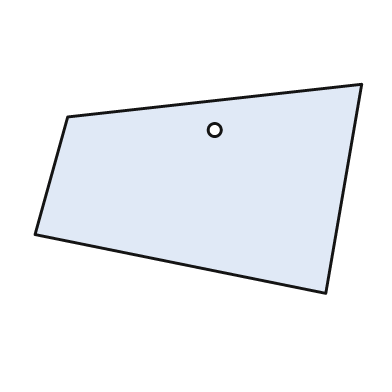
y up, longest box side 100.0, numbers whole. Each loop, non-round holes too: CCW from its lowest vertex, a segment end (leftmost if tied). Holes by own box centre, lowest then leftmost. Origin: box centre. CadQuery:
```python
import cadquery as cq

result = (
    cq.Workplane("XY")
    .moveTo(39.0, -32.0)
    .lineTo(50.0, 32.0)
    .lineTo(-40.0, 22.0)
    .lineTo(-50.0, -14.0)
    .close()
    .moveTo(5.0, 18.0)
    .circle(2.0)
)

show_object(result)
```